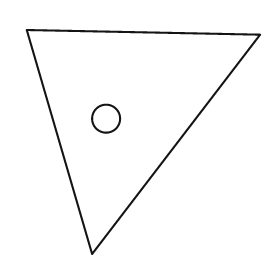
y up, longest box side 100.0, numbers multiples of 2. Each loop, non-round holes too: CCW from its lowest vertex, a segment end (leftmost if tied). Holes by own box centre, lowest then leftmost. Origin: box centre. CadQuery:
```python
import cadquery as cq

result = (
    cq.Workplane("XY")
    .moveTo(-22.0, -48.0)
    .lineTo(50.0, 46.0)
    .lineTo(-50.0, 48.0)
    .close()
    .moveTo(-16.0, 10.0)
    .circle(6.0)
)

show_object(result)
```